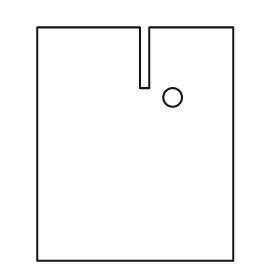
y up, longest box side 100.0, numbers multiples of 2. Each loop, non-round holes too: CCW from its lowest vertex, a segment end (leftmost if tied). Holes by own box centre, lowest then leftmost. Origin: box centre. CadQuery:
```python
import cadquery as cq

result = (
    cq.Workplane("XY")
    .moveTo(-42.0, -50.0)
    .lineTo(42.0, -50.0)
    .lineTo(42.0, 50.0)
    .lineTo(6.0, 50.0)
    .lineTo(6.0, 24.0)
    .lineTo(2.0, 24.0)
    .lineTo(2.0, 50.0)
    .lineTo(-42.0, 50.0)
    .close()
    .moveTo(16.0, 20.0)
    .circle(4.0)
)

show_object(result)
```